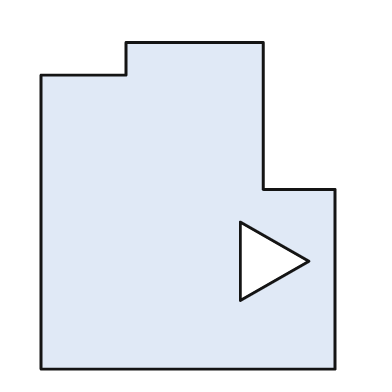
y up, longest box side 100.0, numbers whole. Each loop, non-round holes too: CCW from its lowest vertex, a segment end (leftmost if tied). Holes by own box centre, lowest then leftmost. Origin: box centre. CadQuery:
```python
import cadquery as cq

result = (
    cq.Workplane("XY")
    .moveTo(-45.0, -50.0)
    .lineTo(45.0, -50.0)
    .lineTo(45.0, 5.0)
    .lineTo(23.0, 5.0)
    .lineTo(23.0, 50.0)
    .lineTo(-19.0, 50.0)
    .lineTo(-19.0, 40.0)
    .lineTo(-45.0, 40.0)
    .close()
    .moveTo(16.0, -29.0)
    .lineTo(37.0, -17.0)
    .lineTo(16.0, -5.0)
    .close()
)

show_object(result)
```